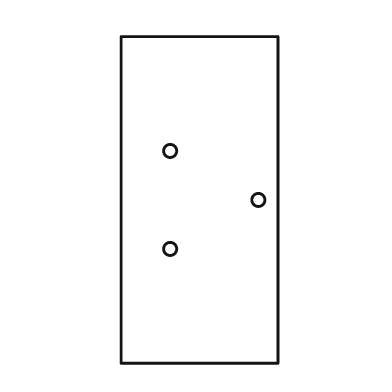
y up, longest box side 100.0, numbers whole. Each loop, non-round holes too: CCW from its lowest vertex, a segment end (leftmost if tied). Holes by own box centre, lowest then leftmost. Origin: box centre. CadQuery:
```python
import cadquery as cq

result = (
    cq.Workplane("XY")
    .moveTo(-24.0, -50.0)
    .lineTo(24.0, -50.0)
    .lineTo(24.0, 50.0)
    .lineTo(-24.0, 50.0)
    .close()
    .moveTo(-9.0, -15.0)
    .circle(2.0)
    .moveTo(18.0, 0.0)
    .circle(2.0)
    .moveTo(-9.0, 15.0)
    .circle(2.0)
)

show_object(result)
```